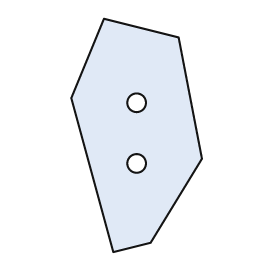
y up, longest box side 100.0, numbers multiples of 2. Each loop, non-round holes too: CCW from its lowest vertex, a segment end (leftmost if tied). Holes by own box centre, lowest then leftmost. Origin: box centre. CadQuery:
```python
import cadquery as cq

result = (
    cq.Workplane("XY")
    .moveTo(-10.0, -50.0)
    .lineTo(6.0, -46.0)
    .lineTo(28.0, -10.0)
    .lineTo(18.0, 42.0)
    .lineTo(-14.0, 50.0)
    .lineTo(-28.0, 16.0)
    .close()
    .moveTo(0.0, -12.0)
    .circle(4.0)
    .moveTo(0.0, 14.0)
    .circle(4.0)
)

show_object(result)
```